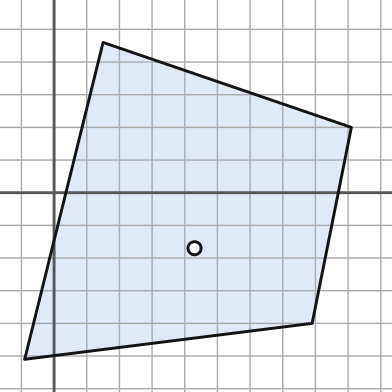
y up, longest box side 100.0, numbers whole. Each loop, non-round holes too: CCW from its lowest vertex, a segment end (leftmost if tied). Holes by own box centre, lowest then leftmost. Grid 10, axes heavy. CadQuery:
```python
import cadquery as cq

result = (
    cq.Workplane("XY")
    .moveTo(-9.0, -51.0)
    .lineTo(79.0, -40.0)
    .lineTo(91.0, 20.0)
    .lineTo(15.0, 46.0)
    .close()
    .moveTo(43.0, -17.0)
    .circle(2.0)
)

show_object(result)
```